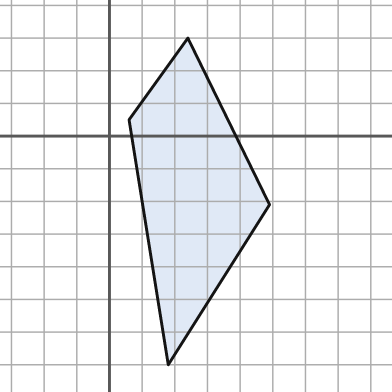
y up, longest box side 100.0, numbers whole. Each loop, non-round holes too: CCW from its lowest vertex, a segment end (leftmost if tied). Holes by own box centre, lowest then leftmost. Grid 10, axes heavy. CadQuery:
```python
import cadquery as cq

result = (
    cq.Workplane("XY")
    .moveTo(18.0, -70.0)
    .lineTo(49.0, -21.0)
    .lineTo(24.0, 30.0)
    .lineTo(6.0, 5.0)
    .close()
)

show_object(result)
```